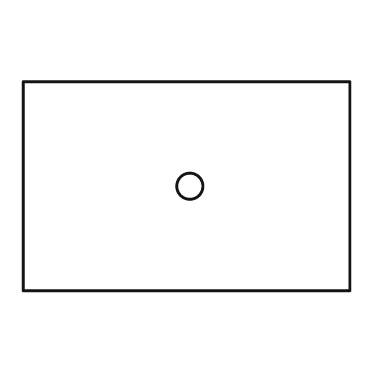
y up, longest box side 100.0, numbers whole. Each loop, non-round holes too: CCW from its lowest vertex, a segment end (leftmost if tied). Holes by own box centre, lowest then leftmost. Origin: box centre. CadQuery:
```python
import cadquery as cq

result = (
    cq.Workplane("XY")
    .moveTo(-50.0, -32.0)
    .lineTo(50.0, -32.0)
    .lineTo(50.0, 32.0)
    .lineTo(-50.0, 32.0)
    .close()
    .moveTo(1.0, 0.0)
    .circle(4.0)
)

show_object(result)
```